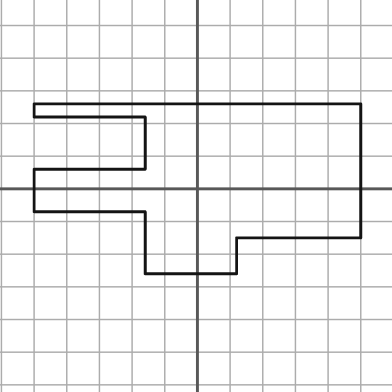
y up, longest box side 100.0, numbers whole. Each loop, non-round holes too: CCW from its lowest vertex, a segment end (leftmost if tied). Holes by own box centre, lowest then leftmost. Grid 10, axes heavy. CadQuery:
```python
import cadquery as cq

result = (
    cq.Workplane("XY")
    .moveTo(-16.0, -26.0)
    .lineTo(12.0, -26.0)
    .lineTo(12.0, -15.0)
    .lineTo(50.0, -15.0)
    .lineTo(50.0, 26.0)
    .lineTo(-50.0, 26.0)
    .lineTo(-50.0, 22.0)
    .lineTo(-16.0, 22.0)
    .lineTo(-16.0, 6.0)
    .lineTo(-50.0, 6.0)
    .lineTo(-50.0, -7.0)
    .lineTo(-16.0, -7.0)
    .close()
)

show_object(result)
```